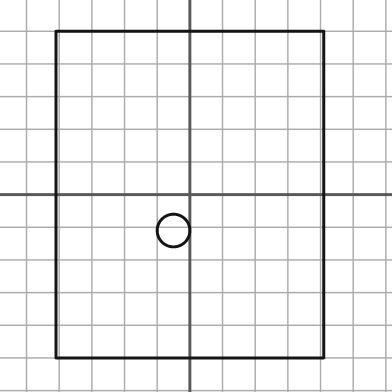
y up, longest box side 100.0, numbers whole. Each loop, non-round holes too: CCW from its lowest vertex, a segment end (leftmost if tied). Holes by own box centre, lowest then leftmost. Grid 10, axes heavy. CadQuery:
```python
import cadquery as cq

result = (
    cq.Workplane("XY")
    .moveTo(-41.0, -50.0)
    .lineTo(41.0, -50.0)
    .lineTo(41.0, 50.0)
    .lineTo(-41.0, 50.0)
    .close()
    .moveTo(-5.0, -11.0)
    .circle(5.0)
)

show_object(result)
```